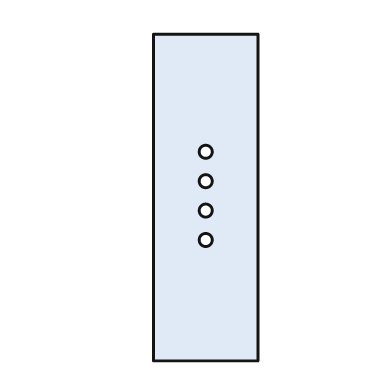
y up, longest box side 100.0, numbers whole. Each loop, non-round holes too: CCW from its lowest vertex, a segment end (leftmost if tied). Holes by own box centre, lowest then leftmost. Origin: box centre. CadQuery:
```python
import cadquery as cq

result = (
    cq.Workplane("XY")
    .moveTo(-16.0, -50.0)
    .lineTo(16.0, -50.0)
    .lineTo(16.0, 50.0)
    .lineTo(-16.0, 50.0)
    .close()
    .moveTo(0.0, -13.0)
    .circle(2.0)
    .moveTo(0.0, -4.0)
    .circle(2.0)
    .moveTo(0.0, 5.0)
    .circle(2.0)
    .moveTo(0.0, 14.0)
    .circle(2.0)
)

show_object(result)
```